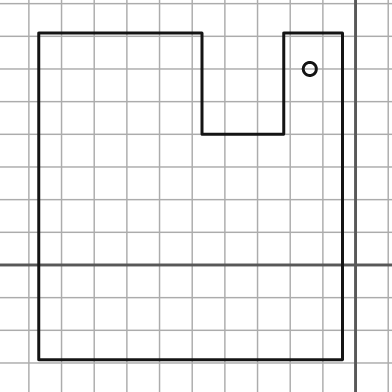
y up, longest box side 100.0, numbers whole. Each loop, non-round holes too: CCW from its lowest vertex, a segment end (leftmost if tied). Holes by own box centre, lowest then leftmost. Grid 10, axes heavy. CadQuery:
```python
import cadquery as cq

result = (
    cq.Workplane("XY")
    .moveTo(-97.0, -29.0)
    .lineTo(-4.0, -29.0)
    .lineTo(-4.0, 71.0)
    .lineTo(-22.0, 71.0)
    .lineTo(-22.0, 40.0)
    .lineTo(-47.0, 40.0)
    .lineTo(-47.0, 71.0)
    .lineTo(-97.0, 71.0)
    .close()
    .moveTo(-14.0, 60.0)
    .circle(2.0)
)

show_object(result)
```